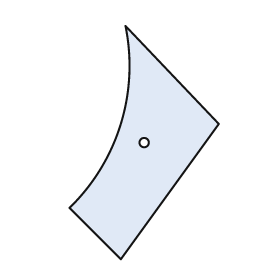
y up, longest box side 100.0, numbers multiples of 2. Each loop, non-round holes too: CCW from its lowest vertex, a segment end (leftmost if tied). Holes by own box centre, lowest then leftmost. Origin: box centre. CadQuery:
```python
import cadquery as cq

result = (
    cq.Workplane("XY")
    .moveTo(-10.0, -50.0)
    .lineTo(32.0, 8.0)
    .lineTo(-8.0, 50.0)
    .threePointArc((-10.0, 8.0), (-32.0, -28.0))
    .close()
    .moveTo(0.0, 0.0)
    .circle(2.0)
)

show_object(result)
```